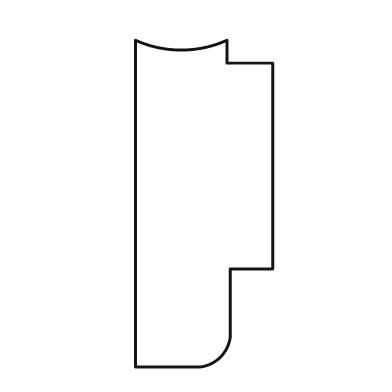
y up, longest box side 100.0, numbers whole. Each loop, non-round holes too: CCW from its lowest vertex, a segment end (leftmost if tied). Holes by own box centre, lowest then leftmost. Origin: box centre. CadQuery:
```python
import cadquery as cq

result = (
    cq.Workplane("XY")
    .moveTo(-21.0, -50.0)
    .lineTo(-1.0, -50.0)
    .threePointArc((5.0, -47.0), (8.0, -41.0))
    .lineTo(8.0, -20.0)
    .lineTo(21.0, -20.0)
    .lineTo(21.0, 43.0)
    .lineTo(7.0, 43.0)
    .lineTo(7.0, 50.0)
    .threePointArc((-7.0, 47.0), (-21.0, 50.0))
    .close()
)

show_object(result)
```